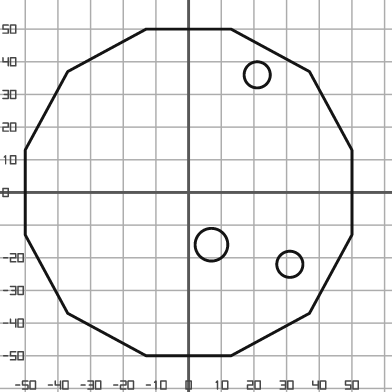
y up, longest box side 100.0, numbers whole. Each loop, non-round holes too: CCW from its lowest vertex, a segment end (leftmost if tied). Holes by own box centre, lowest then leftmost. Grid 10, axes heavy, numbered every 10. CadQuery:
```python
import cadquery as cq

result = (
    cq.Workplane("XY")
    .moveTo(-13.0, -50.0)
    .lineTo(13.0, -50.0)
    .lineTo(37.0, -37.0)
    .lineTo(50.0, -13.0)
    .lineTo(50.0, 13.0)
    .lineTo(37.0, 37.0)
    .lineTo(13.0, 50.0)
    .lineTo(-13.0, 50.0)
    .lineTo(-37.0, 37.0)
    .lineTo(-50.0, 13.0)
    .lineTo(-50.0, -13.0)
    .lineTo(-37.0, -37.0)
    .close()
    .moveTo(31.0, -22.0)
    .circle(4.0)
    .moveTo(7.0, -16.0)
    .circle(5.0)
    .moveTo(21.0, 36.0)
    .circle(4.0)
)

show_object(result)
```